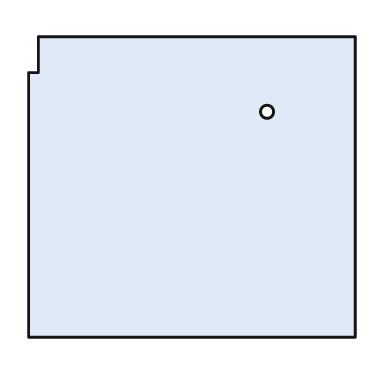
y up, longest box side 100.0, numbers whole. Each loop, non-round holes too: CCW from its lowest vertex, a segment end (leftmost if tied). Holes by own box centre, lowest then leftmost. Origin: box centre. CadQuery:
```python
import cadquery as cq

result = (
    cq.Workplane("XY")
    .moveTo(-50.0, -46.0)
    .lineTo(50.0, -46.0)
    .lineTo(50.0, 46.0)
    .lineTo(-47.0, 46.0)
    .lineTo(-47.0, 35.0)
    .lineTo(-50.0, 35.0)
    .close()
    .moveTo(23.0, 23.0)
    .circle(2.0)
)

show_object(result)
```